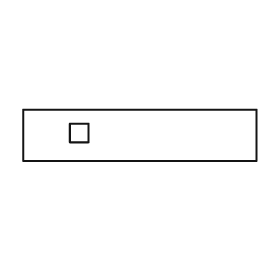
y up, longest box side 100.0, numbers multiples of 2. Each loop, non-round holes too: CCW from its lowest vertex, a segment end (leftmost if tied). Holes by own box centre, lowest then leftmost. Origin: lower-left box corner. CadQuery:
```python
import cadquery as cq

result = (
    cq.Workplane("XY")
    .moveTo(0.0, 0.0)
    .lineTo(100.0, 0.0)
    .lineTo(100.0, 22.0)
    .lineTo(0.0, 22.0)
    .close()
    .moveTo(20.0, 8.0)
    .lineTo(28.0, 8.0)
    .lineTo(28.0, 16.0)
    .lineTo(20.0, 16.0)
    .close()
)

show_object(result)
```